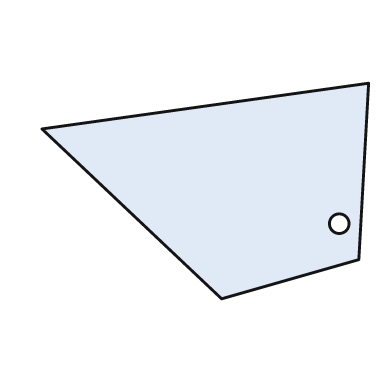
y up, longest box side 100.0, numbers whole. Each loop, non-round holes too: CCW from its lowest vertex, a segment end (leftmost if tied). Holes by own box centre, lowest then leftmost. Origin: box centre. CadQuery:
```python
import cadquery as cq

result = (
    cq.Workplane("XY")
    .moveTo(5.0, -33.0)
    .lineTo(47.0, -21.0)
    .lineTo(50.0, 33.0)
    .lineTo(-50.0, 19.0)
    .close()
    .moveTo(41.0, -10.0)
    .circle(3.0)
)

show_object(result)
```